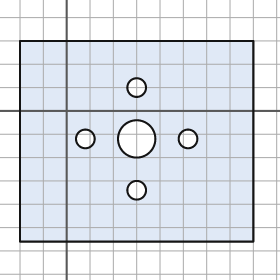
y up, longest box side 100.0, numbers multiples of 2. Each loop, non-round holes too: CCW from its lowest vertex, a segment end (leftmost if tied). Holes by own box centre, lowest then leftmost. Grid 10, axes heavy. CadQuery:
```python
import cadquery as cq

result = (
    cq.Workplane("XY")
    .moveTo(-20.0, -56.0)
    .lineTo(80.0, -56.0)
    .lineTo(80.0, 30.0)
    .lineTo(-20.0, 30.0)
    .close()
    .moveTo(30.0, -34.0)
    .circle(4.0)
    .moveTo(8.0, -12.0)
    .circle(4.0)
    .moveTo(30.0, -12.0)
    .circle(8.0)
    .moveTo(52.0, -12.0)
    .circle(4.0)
    .moveTo(30.0, 10.0)
    .circle(4.0)
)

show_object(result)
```